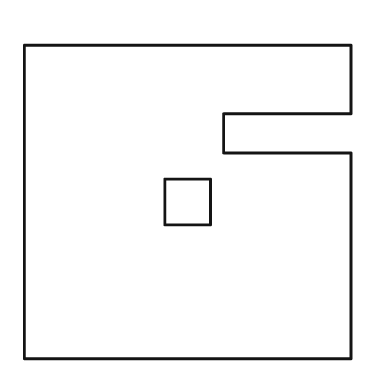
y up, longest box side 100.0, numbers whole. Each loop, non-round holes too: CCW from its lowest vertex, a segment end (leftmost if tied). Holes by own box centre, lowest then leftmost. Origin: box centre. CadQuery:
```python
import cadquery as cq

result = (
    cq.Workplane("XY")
    .moveTo(-50.0, -48.0)
    .lineTo(50.0, -48.0)
    .lineTo(50.0, 15.0)
    .lineTo(11.0, 15.0)
    .lineTo(11.0, 27.0)
    .lineTo(50.0, 27.0)
    .lineTo(50.0, 48.0)
    .lineTo(-50.0, 48.0)
    .close()
    .moveTo(-7.0, -7.0)
    .lineTo(7.0, -7.0)
    .lineTo(7.0, 7.0)
    .lineTo(-7.0, 7.0)
    .close()
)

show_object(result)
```